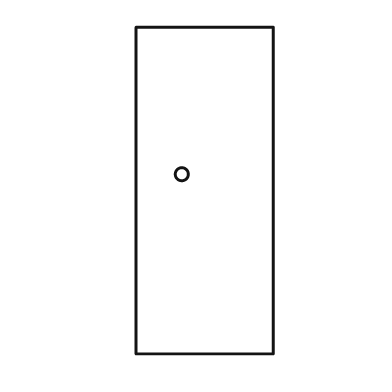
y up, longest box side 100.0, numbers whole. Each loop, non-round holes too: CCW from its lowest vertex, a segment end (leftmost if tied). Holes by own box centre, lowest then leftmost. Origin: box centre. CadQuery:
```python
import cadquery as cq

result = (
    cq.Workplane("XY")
    .moveTo(-21.0, -50.0)
    .lineTo(21.0, -50.0)
    .lineTo(21.0, 50.0)
    .lineTo(-21.0, 50.0)
    .close()
    .moveTo(-7.0, 5.0)
    .circle(2.0)
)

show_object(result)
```